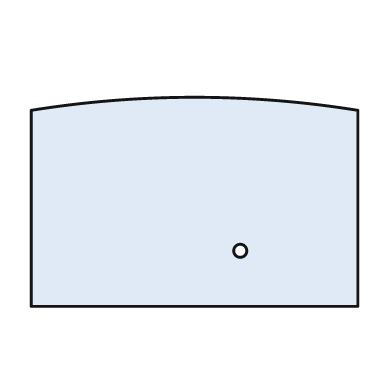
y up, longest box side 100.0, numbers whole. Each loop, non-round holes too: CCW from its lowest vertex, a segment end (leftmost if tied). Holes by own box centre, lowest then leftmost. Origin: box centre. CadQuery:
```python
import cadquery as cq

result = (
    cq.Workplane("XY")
    .moveTo(-50.0, -32.0)
    .lineTo(50.0, -32.0)
    .lineTo(50.0, 28.0)
    .threePointArc((0.0, 32.0), (-50.0, 28.0))
    .close()
    .moveTo(14.0, -15.0)
    .circle(2.0)
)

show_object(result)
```